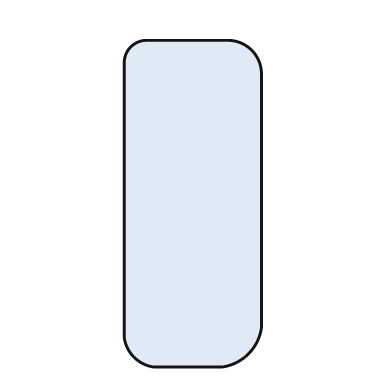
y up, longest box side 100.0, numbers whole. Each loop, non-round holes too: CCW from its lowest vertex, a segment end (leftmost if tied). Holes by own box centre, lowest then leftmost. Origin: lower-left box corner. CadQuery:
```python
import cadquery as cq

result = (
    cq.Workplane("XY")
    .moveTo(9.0, 0.0)
    .lineTo(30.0, 0.0)
    .threePointArc((38.0, 4.0), (42.0, 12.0))
    .lineTo(42.0, 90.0)
    .threePointArc((39.0, 97.0), (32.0, 100.0))
    .lineTo(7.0, 100.0)
    .threePointArc((2.0, 98.0), (0.0, 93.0))
    .lineTo(0.0, 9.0)
    .threePointArc((3.0, 3.0), (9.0, 0.0))
    .close()
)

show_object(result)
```